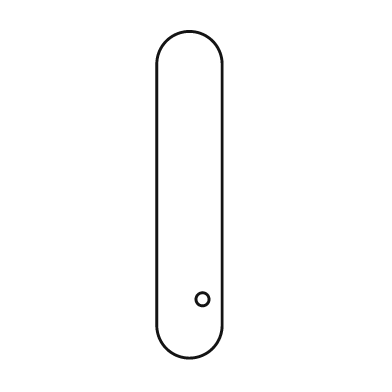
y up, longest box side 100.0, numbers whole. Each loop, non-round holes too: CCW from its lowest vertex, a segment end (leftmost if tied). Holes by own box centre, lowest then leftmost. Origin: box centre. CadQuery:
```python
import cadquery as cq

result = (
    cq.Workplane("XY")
    .moveTo(-10.0, -40.0)
    .threePointArc((0.0, -50.0), (10.0, -40.0))
    .lineTo(10.0, 40.0)
    .threePointArc((0.0, 50.0), (-10.0, 40.0))
    .close()
    .moveTo(4.0, -32.0)
    .circle(2.0)
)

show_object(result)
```